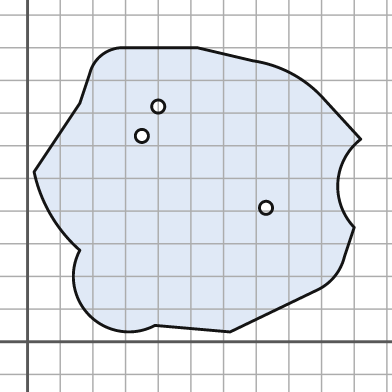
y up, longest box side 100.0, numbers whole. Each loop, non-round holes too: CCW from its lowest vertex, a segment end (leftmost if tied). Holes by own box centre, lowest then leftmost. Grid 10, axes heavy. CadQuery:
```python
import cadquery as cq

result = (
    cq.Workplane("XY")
    .moveTo(62.0, 3.0)
    .lineTo(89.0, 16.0)
    .threePointArc((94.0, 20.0), (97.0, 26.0))
    .lineTo(100.0, 35.0)
    .threePointArc((95.0, 49.0), (102.0, 62.0))
    .lineTo(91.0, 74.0)
    .threePointArc((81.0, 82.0), (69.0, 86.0))
    .lineTo(52.0, 90.0)
    .lineTo(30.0, 90.0)
    .threePointArc((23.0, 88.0), (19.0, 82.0))
    .lineTo(16.0, 73.0)
    .lineTo(2.0, 52.0)
    .threePointArc((7.0, 39.0), (16.0, 28.0))
    .threePointArc((19.0, 8.0), (39.0, 5.0))
    .close()
    .moveTo(73.0, 41.0)
    .circle(2.0)
    .moveTo(35.0, 63.0)
    .circle(2.0)
    .moveTo(40.0, 72.0)
    .circle(2.0)
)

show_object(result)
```